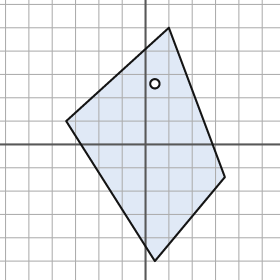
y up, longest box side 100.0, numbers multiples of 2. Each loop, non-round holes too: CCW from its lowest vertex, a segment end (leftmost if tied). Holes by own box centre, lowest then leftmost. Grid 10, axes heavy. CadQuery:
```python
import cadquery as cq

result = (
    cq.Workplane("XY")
    .moveTo(4.0, -50.0)
    .lineTo(34.0, -14.0)
    .lineTo(10.0, 50.0)
    .lineTo(-34.0, 10.0)
    .close()
    .moveTo(4.0, 26.0)
    .circle(2.0)
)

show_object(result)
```